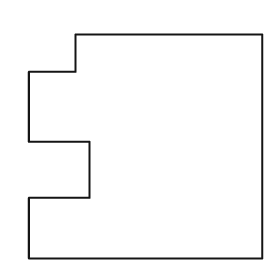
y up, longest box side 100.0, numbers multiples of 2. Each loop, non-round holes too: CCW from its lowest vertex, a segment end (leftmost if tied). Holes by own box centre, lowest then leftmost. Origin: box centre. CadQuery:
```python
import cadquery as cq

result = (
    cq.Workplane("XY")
    .moveTo(-50.0, -48.0)
    .lineTo(50.0, -48.0)
    .lineTo(50.0, 48.0)
    .lineTo(-30.0, 48.0)
    .lineTo(-30.0, 32.0)
    .lineTo(-50.0, 32.0)
    .lineTo(-50.0, 2.0)
    .lineTo(-24.0, 2.0)
    .lineTo(-24.0, -22.0)
    .lineTo(-50.0, -22.0)
    .close()
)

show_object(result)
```